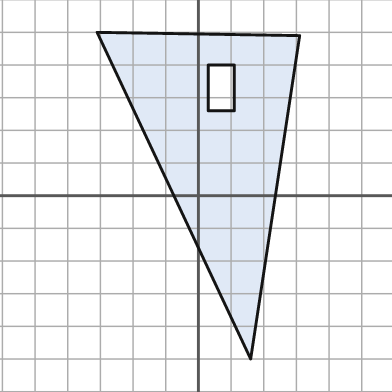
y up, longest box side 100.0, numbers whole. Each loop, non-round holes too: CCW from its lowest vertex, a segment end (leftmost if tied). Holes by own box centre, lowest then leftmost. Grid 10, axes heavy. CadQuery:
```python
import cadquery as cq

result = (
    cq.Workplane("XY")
    .moveTo(16.0, -50.0)
    .lineTo(31.0, 49.0)
    .lineTo(-31.0, 50.0)
    .close()
    .moveTo(3.0, 26.0)
    .lineTo(11.0, 26.0)
    .lineTo(11.0, 40.0)
    .lineTo(3.0, 40.0)
    .close()
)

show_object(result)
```